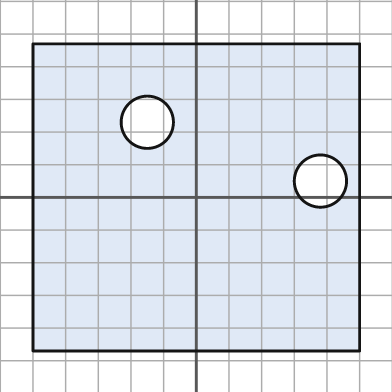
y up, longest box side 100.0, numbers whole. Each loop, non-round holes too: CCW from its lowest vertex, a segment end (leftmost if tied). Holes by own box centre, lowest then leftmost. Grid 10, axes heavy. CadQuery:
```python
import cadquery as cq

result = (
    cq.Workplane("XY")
    .moveTo(-50.0, -47.0)
    .lineTo(50.0, -47.0)
    .lineTo(50.0, 47.0)
    .lineTo(-50.0, 47.0)
    .close()
    .moveTo(38.0, 5.0)
    .circle(8.0)
    .moveTo(-15.0, 23.0)
    .circle(8.0)
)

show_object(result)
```